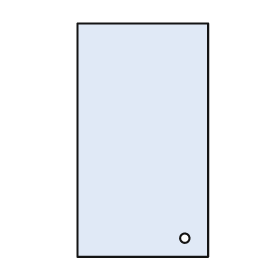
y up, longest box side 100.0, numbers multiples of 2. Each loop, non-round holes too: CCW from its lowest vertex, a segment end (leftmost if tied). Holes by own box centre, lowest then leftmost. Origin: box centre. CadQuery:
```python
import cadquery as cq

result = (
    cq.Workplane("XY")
    .moveTo(-28.0, -50.0)
    .lineTo(28.0, -50.0)
    .lineTo(28.0, 50.0)
    .lineTo(-28.0, 50.0)
    .close()
    .moveTo(18.0, -42.0)
    .circle(2.0)
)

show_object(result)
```